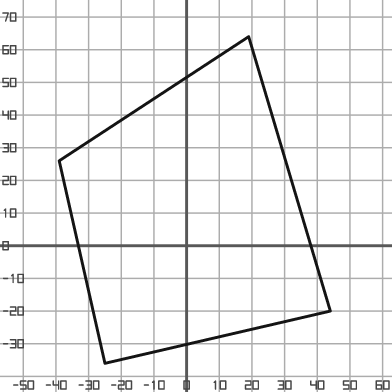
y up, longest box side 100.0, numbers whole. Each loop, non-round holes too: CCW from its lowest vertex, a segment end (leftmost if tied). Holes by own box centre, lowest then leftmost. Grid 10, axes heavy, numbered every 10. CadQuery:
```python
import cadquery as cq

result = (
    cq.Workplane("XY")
    .moveTo(-25.0, -36.0)
    .lineTo(44.0, -20.0)
    .lineTo(19.0, 64.0)
    .lineTo(-39.0, 26.0)
    .close()
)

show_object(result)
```